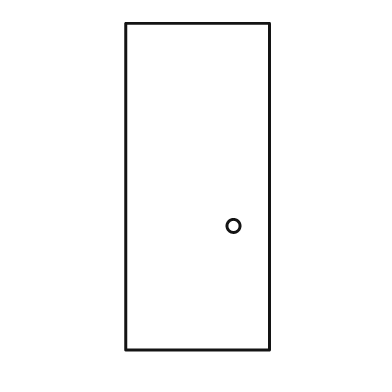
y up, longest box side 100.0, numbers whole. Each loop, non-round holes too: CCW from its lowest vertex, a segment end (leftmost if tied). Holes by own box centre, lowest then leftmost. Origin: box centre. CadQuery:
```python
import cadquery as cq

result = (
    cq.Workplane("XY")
    .moveTo(-22.0, -50.0)
    .lineTo(22.0, -50.0)
    .lineTo(22.0, 50.0)
    .lineTo(-22.0, 50.0)
    .close()
    .moveTo(11.0, -12.0)
    .circle(2.0)
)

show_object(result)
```